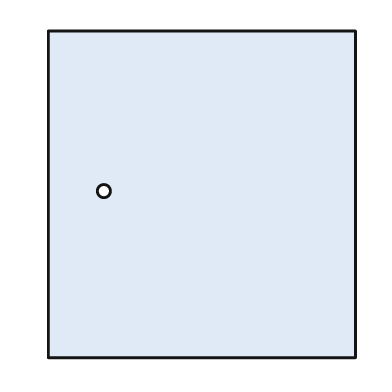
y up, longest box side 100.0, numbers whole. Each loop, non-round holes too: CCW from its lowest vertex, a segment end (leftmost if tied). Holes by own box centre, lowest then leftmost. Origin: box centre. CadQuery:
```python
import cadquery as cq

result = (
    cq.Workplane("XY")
    .moveTo(-47.0, -50.0)
    .lineTo(47.0, -50.0)
    .lineTo(47.0, 50.0)
    .lineTo(-47.0, 50.0)
    .close()
    .moveTo(-30.0, 1.0)
    .circle(2.0)
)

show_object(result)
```